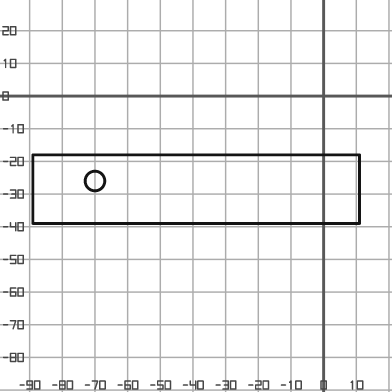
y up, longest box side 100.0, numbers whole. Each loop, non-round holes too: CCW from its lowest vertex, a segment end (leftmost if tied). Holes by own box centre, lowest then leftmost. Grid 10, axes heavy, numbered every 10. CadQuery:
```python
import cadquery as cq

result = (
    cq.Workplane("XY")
    .moveTo(-89.0, -39.0)
    .lineTo(11.0, -39.0)
    .lineTo(11.0, -18.0)
    .lineTo(-89.0, -18.0)
    .close()
    .moveTo(-70.0, -26.0)
    .circle(3.0)
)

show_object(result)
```